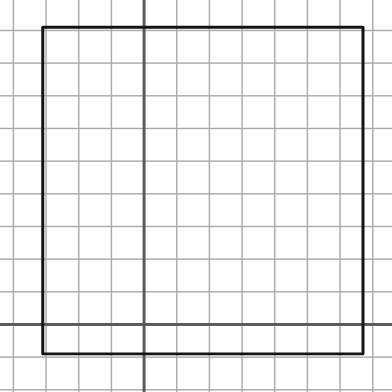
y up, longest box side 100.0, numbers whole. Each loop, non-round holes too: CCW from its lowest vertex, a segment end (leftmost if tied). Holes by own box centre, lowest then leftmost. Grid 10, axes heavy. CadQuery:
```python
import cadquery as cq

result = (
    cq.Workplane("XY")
    .moveTo(-31.0, -9.0)
    .lineTo(67.0, -9.0)
    .lineTo(67.0, 91.0)
    .lineTo(-31.0, 91.0)
    .close()
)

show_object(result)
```